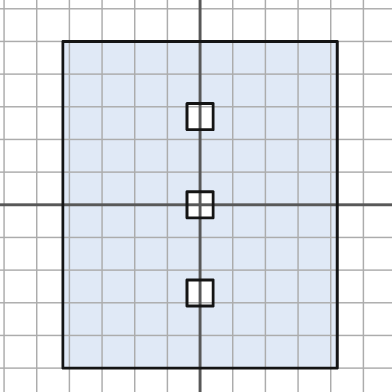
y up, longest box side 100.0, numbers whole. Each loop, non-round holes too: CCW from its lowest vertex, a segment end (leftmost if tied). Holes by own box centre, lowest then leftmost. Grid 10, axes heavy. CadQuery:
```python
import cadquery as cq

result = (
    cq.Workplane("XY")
    .moveTo(-42.0, -50.0)
    .lineTo(42.0, -50.0)
    .lineTo(42.0, 50.0)
    .lineTo(-42.0, 50.0)
    .close()
    .moveTo(-4.0, -31.0)
    .lineTo(4.0, -31.0)
    .lineTo(4.0, -23.0)
    .lineTo(-4.0, -23.0)
    .close()
    .moveTo(-4.0, -4.0)
    .lineTo(4.0, -4.0)
    .lineTo(4.0, 4.0)
    .lineTo(-4.0, 4.0)
    .close()
    .moveTo(-4.0, 23.0)
    .lineTo(4.0, 23.0)
    .lineTo(4.0, 31.0)
    .lineTo(-4.0, 31.0)
    .close()
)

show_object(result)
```